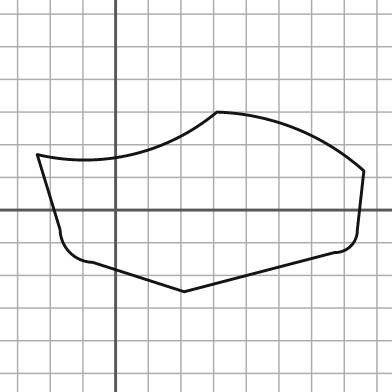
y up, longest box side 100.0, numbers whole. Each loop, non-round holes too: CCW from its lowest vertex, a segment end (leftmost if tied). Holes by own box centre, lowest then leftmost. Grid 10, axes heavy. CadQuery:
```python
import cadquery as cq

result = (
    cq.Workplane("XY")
    .moveTo(21.0, -25.0)
    .lineTo(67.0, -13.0)
    .threePointArc((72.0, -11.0), (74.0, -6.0))
    .lineTo(76.0, 12.0)
    .threePointArc((55.0, 25.0), (31.0, 30.0))
    .threePointArc((5.0, 17.0), (-24.0, 17.0))
    .lineTo(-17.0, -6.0)
    .threePointArc((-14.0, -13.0), (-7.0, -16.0))
    .close()
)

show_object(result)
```